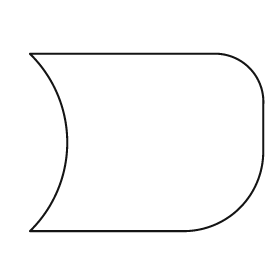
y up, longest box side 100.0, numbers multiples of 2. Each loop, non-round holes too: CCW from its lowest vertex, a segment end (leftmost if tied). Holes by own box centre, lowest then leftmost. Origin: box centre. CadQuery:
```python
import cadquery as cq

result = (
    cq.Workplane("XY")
    .moveTo(-50.0, -38.0)
    .lineTo(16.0, -38.0)
    .threePointArc((40.0, -28.0), (50.0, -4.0))
    .lineTo(50.0, 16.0)
    .threePointArc((44.0, 32.0), (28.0, 38.0))
    .lineTo(-50.0, 38.0)
    .threePointArc((-34.0, 0.0), (-50.0, -38.0))
    .close()
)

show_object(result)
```